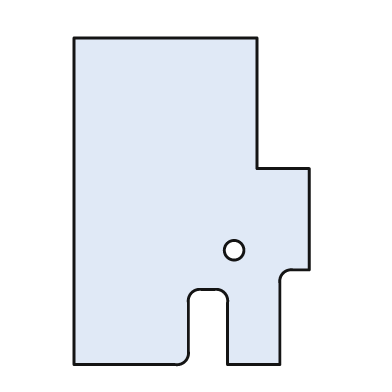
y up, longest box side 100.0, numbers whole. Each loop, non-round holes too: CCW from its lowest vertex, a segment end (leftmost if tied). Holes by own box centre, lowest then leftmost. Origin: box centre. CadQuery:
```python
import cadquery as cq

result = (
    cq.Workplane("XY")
    .moveTo(-36.0, -50.0)
    .lineTo(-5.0, -50.0)
    .threePointArc((-2.0, -49.0), (-1.0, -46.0))
    .lineTo(-1.0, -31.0)
    .threePointArc((0.0, -28.0), (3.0, -27.0))
    .lineTo(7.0, -27.0)
    .threePointArc((10.0, -28.0), (11.0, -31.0))
    .lineTo(11.0, -50.0)
    .lineTo(27.0, -50.0)
    .lineTo(27.0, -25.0)
    .threePointArc((28.0, -22.0), (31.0, -21.0))
    .lineTo(36.0, -21.0)
    .lineTo(36.0, 10.0)
    .lineTo(20.0, 10.0)
    .lineTo(20.0, 50.0)
    .lineTo(-36.0, 50.0)
    .close()
    .moveTo(13.0, -15.0)
    .circle(3.0)
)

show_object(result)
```